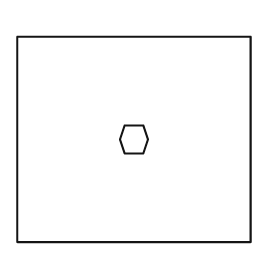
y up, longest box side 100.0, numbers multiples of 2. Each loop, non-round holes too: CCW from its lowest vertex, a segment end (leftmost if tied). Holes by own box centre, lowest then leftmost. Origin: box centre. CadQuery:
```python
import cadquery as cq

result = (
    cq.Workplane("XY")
    .moveTo(-50.0, -44.0)
    .lineTo(50.0, -44.0)
    .lineTo(50.0, 44.0)
    .lineTo(-50.0, 44.0)
    .close()
    .moveTo(-4.0, -6.0)
    .lineTo(4.0, -6.0)
    .lineTo(6.0, 0.0)
    .lineTo(4.0, 6.0)
    .lineTo(-4.0, 6.0)
    .lineTo(-6.0, 0.0)
    .close()
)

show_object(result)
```